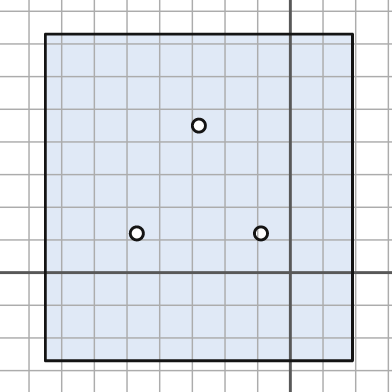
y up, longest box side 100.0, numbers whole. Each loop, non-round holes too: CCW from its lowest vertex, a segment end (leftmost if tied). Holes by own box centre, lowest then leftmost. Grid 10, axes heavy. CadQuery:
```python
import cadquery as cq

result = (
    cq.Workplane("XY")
    .moveTo(-75.0, -27.0)
    .lineTo(19.0, -27.0)
    .lineTo(19.0, 73.0)
    .lineTo(-75.0, 73.0)
    .close()
    .moveTo(-47.0, 12.0)
    .circle(2.0)
    .moveTo(-9.0, 12.0)
    .circle(2.0)
    .moveTo(-28.0, 45.0)
    .circle(2.0)
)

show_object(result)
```